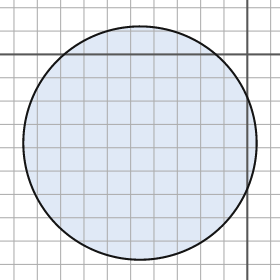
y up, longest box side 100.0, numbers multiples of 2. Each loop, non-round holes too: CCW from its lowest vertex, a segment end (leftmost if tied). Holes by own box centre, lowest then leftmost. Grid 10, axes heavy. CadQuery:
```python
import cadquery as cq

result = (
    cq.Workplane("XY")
    .moveTo(-46.0, -38.0)
    .circle(50.0)
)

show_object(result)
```